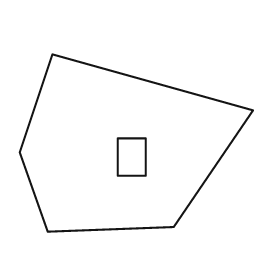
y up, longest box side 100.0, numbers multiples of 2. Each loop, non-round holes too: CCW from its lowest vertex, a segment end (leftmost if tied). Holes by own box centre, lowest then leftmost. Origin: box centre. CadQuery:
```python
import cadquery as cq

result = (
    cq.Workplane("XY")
    .moveTo(-38.0, -38.0)
    .lineTo(16.0, -36.0)
    .lineTo(50.0, 14.0)
    .lineTo(-36.0, 38.0)
    .lineTo(-50.0, -4.0)
    .close()
    .moveTo(-8.0, -14.0)
    .lineTo(4.0, -14.0)
    .lineTo(4.0, 2.0)
    .lineTo(-8.0, 2.0)
    .close()
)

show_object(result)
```